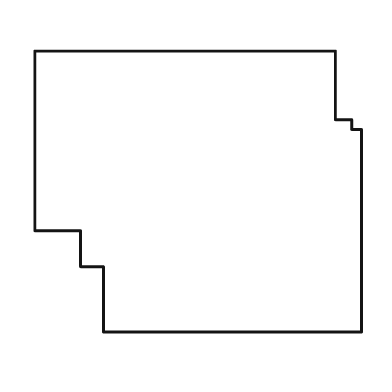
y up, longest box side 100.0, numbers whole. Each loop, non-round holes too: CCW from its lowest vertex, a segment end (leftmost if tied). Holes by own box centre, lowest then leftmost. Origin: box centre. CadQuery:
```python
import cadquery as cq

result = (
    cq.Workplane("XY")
    .moveTo(-29.0, -43.0)
    .lineTo(50.0, -43.0)
    .lineTo(50.0, 19.0)
    .lineTo(47.0, 19.0)
    .lineTo(47.0, 22.0)
    .lineTo(42.0, 22.0)
    .lineTo(42.0, 43.0)
    .lineTo(-50.0, 43.0)
    .lineTo(-50.0, -12.0)
    .lineTo(-36.0, -12.0)
    .lineTo(-36.0, -23.0)
    .lineTo(-29.0, -23.0)
    .close()
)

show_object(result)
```